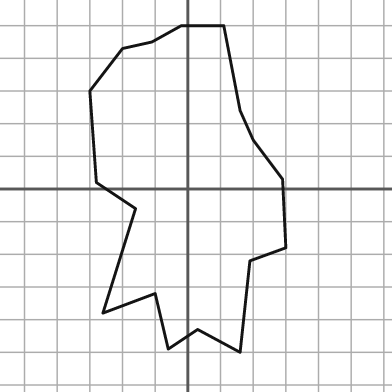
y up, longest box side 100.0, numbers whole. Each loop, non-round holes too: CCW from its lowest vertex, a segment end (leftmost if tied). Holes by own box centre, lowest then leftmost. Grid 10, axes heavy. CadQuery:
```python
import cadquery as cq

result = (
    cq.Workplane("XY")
    .moveTo(16.0, -50.0)
    .lineTo(19.0, -22.0)
    .lineTo(30.0, -18.0)
    .lineTo(29.0, 3.0)
    .lineTo(20.0, 15.0)
    .lineTo(16.0, 24.0)
    .lineTo(11.0, 50.0)
    .lineTo(-2.0, 50.0)
    .lineTo(-11.0, 45.0)
    .lineTo(-20.0, 43.0)
    .lineTo(-30.0, 30.0)
    .lineTo(-28.0, 2.0)
    .lineTo(-16.0, -6.0)
    .lineTo(-26.0, -38.0)
    .lineTo(-10.0, -32.0)
    .lineTo(-6.0, -49.0)
    .lineTo(3.0, -43.0)
    .close()
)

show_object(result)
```